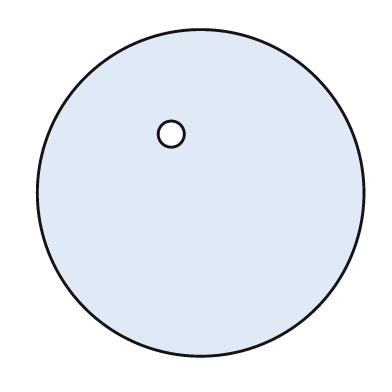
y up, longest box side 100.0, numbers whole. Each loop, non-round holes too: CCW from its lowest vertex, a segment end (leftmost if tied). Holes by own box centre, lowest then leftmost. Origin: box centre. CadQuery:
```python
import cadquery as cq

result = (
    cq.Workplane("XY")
    .moveTo(0.0, 0.0)
    .circle(50.0)
    .moveTo(-9.0, 18.0)
    .circle(4.0)
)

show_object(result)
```